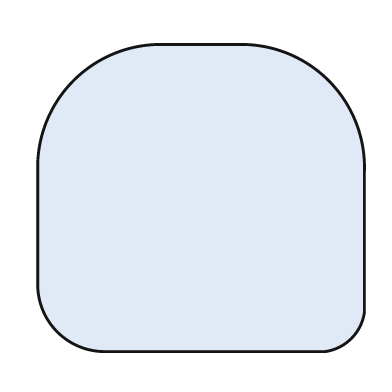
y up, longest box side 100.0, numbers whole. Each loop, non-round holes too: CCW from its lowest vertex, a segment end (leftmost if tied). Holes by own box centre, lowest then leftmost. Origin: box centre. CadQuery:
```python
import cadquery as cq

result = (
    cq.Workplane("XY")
    .moveTo(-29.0, -47.0)
    .lineTo(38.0, -47.0)
    .threePointArc((46.0, -43.0), (50.0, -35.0))
    .lineTo(50.0, 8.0)
    .threePointArc((39.0, 36.0), (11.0, 47.0))
    .lineTo(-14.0, 47.0)
    .threePointArc((-39.0, 36.0), (-50.0, 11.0))
    .lineTo(-50.0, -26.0)
    .threePointArc((-44.0, -41.0), (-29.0, -47.0))
    .close()
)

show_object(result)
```